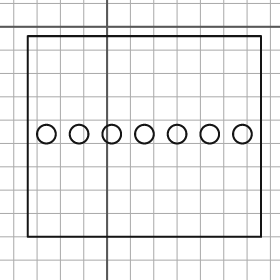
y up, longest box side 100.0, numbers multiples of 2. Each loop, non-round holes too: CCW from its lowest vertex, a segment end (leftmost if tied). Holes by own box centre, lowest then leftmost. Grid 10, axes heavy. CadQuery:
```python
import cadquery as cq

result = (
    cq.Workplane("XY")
    .moveTo(-34.0, -90.0)
    .lineTo(66.0, -90.0)
    .lineTo(66.0, -4.0)
    .lineTo(-34.0, -4.0)
    .close()
    .moveTo(-26.0, -46.0)
    .circle(4.0)
    .moveTo(-12.0, -46.0)
    .circle(4.0)
    .moveTo(2.0, -46.0)
    .circle(4.0)
    .moveTo(16.0, -46.0)
    .circle(4.0)
    .moveTo(30.0, -46.0)
    .circle(4.0)
    .moveTo(44.0, -46.0)
    .circle(4.0)
    .moveTo(58.0, -46.0)
    .circle(4.0)
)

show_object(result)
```